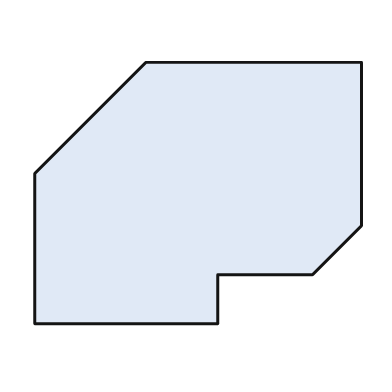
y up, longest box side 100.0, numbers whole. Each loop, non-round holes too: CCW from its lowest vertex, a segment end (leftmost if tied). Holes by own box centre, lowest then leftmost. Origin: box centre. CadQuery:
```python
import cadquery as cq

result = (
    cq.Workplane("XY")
    .moveTo(-50.0, -40.0)
    .lineTo(6.0, -40.0)
    .lineTo(6.0, -25.0)
    .lineTo(35.0, -25.0)
    .lineTo(50.0, -10.0)
    .lineTo(50.0, 40.0)
    .lineTo(-16.0, 40.0)
    .lineTo(-50.0, 6.0)
    .close()
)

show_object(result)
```